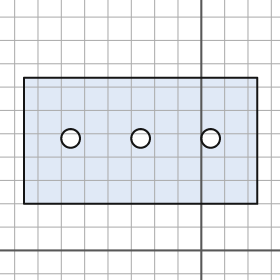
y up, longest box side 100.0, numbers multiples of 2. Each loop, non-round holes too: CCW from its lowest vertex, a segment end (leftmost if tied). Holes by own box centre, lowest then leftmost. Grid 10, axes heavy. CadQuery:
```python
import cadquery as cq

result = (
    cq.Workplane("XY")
    .moveTo(-76.0, 20.0)
    .lineTo(24.0, 20.0)
    .lineTo(24.0, 74.0)
    .lineTo(-76.0, 74.0)
    .close()
    .moveTo(-56.0, 48.0)
    .circle(4.0)
    .moveTo(-26.0, 48.0)
    .circle(4.0)
    .moveTo(4.0, 48.0)
    .circle(4.0)
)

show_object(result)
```